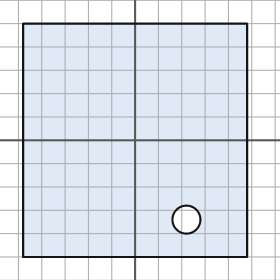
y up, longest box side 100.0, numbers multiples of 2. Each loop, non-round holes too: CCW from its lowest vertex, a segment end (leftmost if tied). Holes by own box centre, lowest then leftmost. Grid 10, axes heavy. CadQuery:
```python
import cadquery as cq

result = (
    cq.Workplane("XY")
    .moveTo(-48.0, -50.0)
    .lineTo(48.0, -50.0)
    .lineTo(48.0, 50.0)
    .lineTo(-48.0, 50.0)
    .close()
    .moveTo(22.0, -34.0)
    .circle(6.0)
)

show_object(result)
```